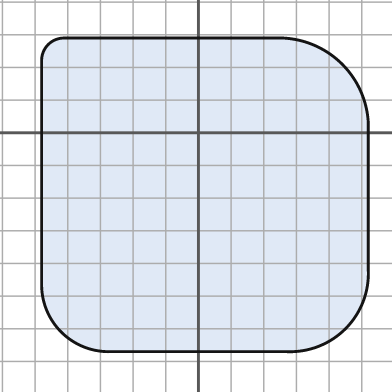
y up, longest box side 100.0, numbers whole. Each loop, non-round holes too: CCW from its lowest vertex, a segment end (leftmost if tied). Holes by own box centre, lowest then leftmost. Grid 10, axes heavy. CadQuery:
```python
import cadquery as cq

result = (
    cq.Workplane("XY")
    .moveTo(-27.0, -67.0)
    .lineTo(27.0, -67.0)
    .threePointArc((45.0, -60.0), (52.0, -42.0))
    .lineTo(52.0, 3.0)
    .threePointArc((44.0, 21.0), (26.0, 29.0))
    .lineTo(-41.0, 29.0)
    .threePointArc((-46.0, 27.0), (-48.0, 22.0))
    .lineTo(-48.0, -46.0)
    .threePointArc((-42.0, -61.0), (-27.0, -67.0))
    .close()
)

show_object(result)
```